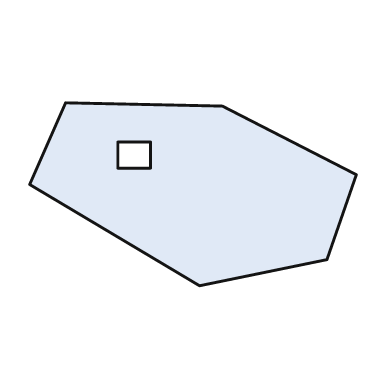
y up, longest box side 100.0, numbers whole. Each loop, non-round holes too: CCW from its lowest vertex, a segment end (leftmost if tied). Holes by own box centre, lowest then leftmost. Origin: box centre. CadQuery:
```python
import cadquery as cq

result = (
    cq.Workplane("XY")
    .moveTo(2.0, -28.0)
    .lineTo(41.0, -20.0)
    .lineTo(50.0, 6.0)
    .lineTo(9.0, 27.0)
    .lineTo(-39.0, 28.0)
    .lineTo(-50.0, 3.0)
    .close()
    .moveTo(-23.0, 8.0)
    .lineTo(-13.0, 8.0)
    .lineTo(-13.0, 16.0)
    .lineTo(-23.0, 16.0)
    .close()
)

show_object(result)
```